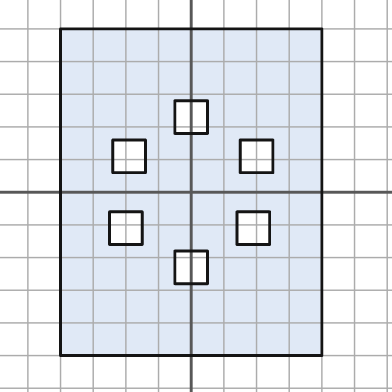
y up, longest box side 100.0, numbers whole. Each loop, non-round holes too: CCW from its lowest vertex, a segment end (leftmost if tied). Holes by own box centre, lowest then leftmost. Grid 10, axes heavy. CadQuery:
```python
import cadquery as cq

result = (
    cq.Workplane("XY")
    .moveTo(-40.0, -50.0)
    .lineTo(40.0, -50.0)
    .lineTo(40.0, 50.0)
    .lineTo(-40.0, 50.0)
    .close()
    .moveTo(-5.0, -28.0)
    .lineTo(5.0, -28.0)
    .lineTo(5.0, -18.0)
    .lineTo(-5.0, -18.0)
    .close()
    .moveTo(-25.0, -16.0)
    .lineTo(-15.0, -16.0)
    .lineTo(-15.0, -6.0)
    .lineTo(-25.0, -6.0)
    .close()
    .moveTo(14.0, -16.0)
    .lineTo(24.0, -16.0)
    .lineTo(24.0, -6.0)
    .lineTo(14.0, -6.0)
    .close()
    .moveTo(-24.0, 6.0)
    .lineTo(-14.0, 6.0)
    .lineTo(-14.0, 16.0)
    .lineTo(-24.0, 16.0)
    .close()
    .moveTo(15.0, 6.0)
    .lineTo(25.0, 6.0)
    .lineTo(25.0, 16.0)
    .lineTo(15.0, 16.0)
    .close()
    .moveTo(-5.0, 18.0)
    .lineTo(5.0, 18.0)
    .lineTo(5.0, 28.0)
    .lineTo(-5.0, 28.0)
    .close()
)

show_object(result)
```